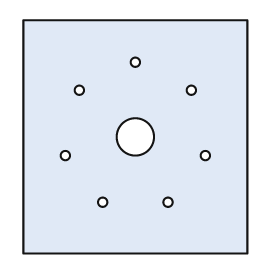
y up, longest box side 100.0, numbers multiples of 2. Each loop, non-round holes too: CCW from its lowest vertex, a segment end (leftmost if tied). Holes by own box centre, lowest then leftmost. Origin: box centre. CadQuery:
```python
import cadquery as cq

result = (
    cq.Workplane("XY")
    .moveTo(-48.0, -50.0)
    .lineTo(48.0, -50.0)
    .lineTo(48.0, 50.0)
    .lineTo(-48.0, 50.0)
    .close()
    .moveTo(-14.0, -28.0)
    .circle(2.0)
    .moveTo(14.0, -28.0)
    .circle(2.0)
    .moveTo(-30.0, -8.0)
    .circle(2.0)
    .moveTo(30.0, -8.0)
    .circle(2.0)
    .moveTo(0.0, 0.0)
    .circle(8.0)
    .moveTo(-24.0, 20.0)
    .circle(2.0)
    .moveTo(24.0, 20.0)
    .circle(2.0)
    .moveTo(0.0, 32.0)
    .circle(2.0)
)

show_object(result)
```